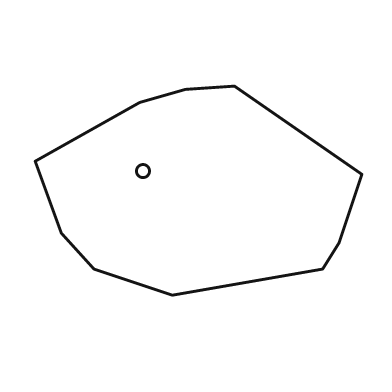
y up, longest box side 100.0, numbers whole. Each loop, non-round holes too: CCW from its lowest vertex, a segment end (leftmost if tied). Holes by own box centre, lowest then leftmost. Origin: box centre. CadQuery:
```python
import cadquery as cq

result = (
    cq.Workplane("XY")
    .moveTo(-8.0, -32.0)
    .lineTo(38.0, -24.0)
    .lineTo(43.0, -16.0)
    .lineTo(50.0, 5.0)
    .lineTo(11.0, 32.0)
    .lineTo(-4.0, 31.0)
    .lineTo(-18.0, 27.0)
    .lineTo(-50.0, 9.0)
    .lineTo(-42.0, -13.0)
    .lineTo(-32.0, -24.0)
    .close()
    .moveTo(-17.0, 6.0)
    .circle(2.0)
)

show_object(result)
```